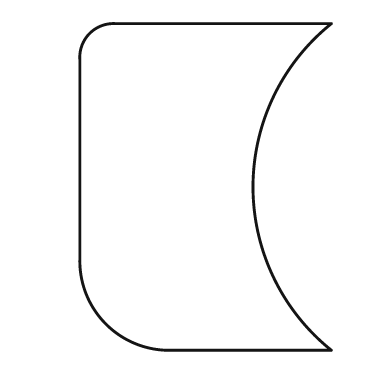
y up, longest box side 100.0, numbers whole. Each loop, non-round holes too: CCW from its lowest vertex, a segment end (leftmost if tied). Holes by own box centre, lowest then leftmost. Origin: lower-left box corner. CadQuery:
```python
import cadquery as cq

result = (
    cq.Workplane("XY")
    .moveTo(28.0, 0.0)
    .lineTo(77.0, 0.0)
    .threePointArc((53.0, 50.0), (77.0, 100.0))
    .lineTo(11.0, 100.0)
    .threePointArc((3.0, 97.0), (0.0, 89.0))
    .lineTo(0.0, 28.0)
    .threePointArc((8.0, 8.0), (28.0, 0.0))
    .close()
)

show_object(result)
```